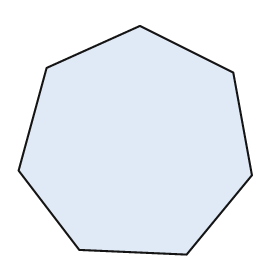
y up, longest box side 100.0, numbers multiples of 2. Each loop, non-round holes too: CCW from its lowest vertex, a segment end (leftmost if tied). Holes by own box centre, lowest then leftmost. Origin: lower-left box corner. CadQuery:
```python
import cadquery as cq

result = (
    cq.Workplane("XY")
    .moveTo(72.0, 0.0)
    .lineTo(100.0, 34.0)
    .lineTo(92.0, 78.0)
    .lineTo(52.0, 98.0)
    .lineTo(12.0, 80.0)
    .lineTo(0.0, 36.0)
    .lineTo(26.0, 2.0)
    .close()
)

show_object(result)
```